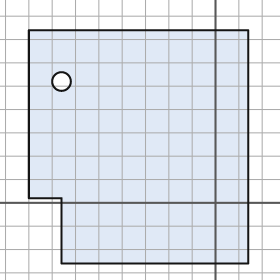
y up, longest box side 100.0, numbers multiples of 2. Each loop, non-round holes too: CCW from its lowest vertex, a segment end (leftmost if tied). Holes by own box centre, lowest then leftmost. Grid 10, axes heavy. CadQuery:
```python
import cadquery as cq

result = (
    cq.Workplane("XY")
    .moveTo(-66.0, -26.0)
    .lineTo(14.0, -26.0)
    .lineTo(14.0, 74.0)
    .lineTo(-80.0, 74.0)
    .lineTo(-80.0, 2.0)
    .lineTo(-66.0, 2.0)
    .close()
    .moveTo(-66.0, 52.0)
    .circle(4.0)
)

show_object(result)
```